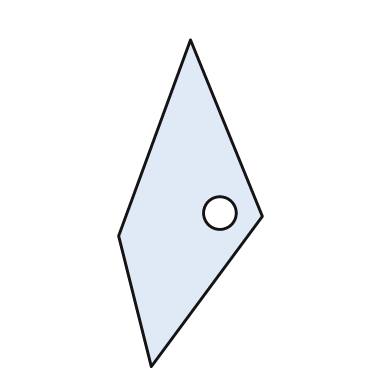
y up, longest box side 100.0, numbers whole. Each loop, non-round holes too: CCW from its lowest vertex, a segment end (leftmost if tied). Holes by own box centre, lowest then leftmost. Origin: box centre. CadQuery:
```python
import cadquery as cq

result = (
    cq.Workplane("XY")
    .moveTo(-12.0, -50.0)
    .lineTo(22.0, -4.0)
    .lineTo(0.0, 50.0)
    .lineTo(-22.0, -10.0)
    .close()
    .moveTo(9.0, -3.0)
    .circle(5.0)
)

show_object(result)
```